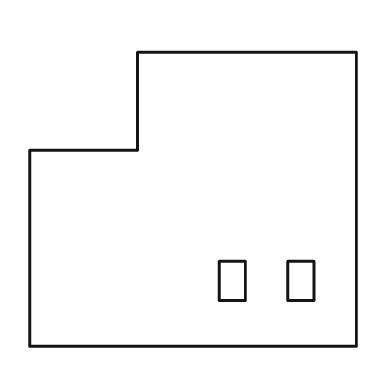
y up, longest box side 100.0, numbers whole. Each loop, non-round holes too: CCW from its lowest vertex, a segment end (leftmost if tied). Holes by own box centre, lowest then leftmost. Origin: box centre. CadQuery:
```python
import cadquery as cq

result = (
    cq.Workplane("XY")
    .moveTo(-50.0, -45.0)
    .lineTo(50.0, -45.0)
    .lineTo(50.0, 45.0)
    .lineTo(-17.0, 45.0)
    .lineTo(-17.0, 15.0)
    .lineTo(-50.0, 15.0)
    .close()
    .moveTo(8.0, -31.0)
    .lineTo(16.0, -31.0)
    .lineTo(16.0, -19.0)
    .lineTo(8.0, -19.0)
    .close()
    .moveTo(29.0, -31.0)
    .lineTo(37.0, -31.0)
    .lineTo(37.0, -19.0)
    .lineTo(29.0, -19.0)
    .close()
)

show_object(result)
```